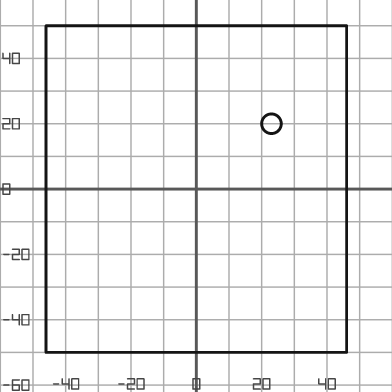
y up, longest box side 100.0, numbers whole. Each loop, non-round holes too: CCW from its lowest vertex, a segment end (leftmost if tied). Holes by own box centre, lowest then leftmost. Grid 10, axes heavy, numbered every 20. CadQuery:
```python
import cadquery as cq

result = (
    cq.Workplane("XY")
    .moveTo(-46.0, -50.0)
    .lineTo(46.0, -50.0)
    .lineTo(46.0, 50.0)
    .lineTo(-46.0, 50.0)
    .close()
    .moveTo(23.0, 20.0)
    .circle(3.0)
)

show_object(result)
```